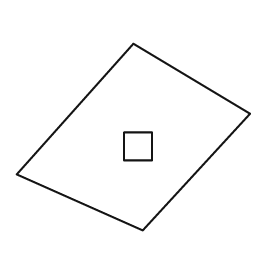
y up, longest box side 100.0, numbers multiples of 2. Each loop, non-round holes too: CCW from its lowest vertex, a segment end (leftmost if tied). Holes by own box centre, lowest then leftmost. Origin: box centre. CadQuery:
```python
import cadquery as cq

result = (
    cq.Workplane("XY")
    .moveTo(4.0, -40.0)
    .lineTo(50.0, 10.0)
    .lineTo(0.0, 40.0)
    .lineTo(-50.0, -16.0)
    .close()
    .moveTo(-4.0, -10.0)
    .lineTo(8.0, -10.0)
    .lineTo(8.0, 2.0)
    .lineTo(-4.0, 2.0)
    .close()
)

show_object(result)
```